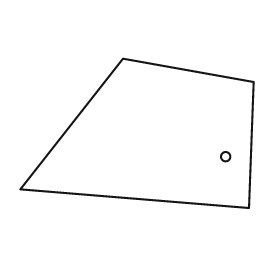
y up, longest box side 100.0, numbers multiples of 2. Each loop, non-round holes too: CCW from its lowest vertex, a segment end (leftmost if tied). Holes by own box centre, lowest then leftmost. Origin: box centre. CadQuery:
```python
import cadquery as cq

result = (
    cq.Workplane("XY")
    .moveTo(48.0, -32.0)
    .lineTo(50.0, 22.0)
    .lineTo(-6.0, 32.0)
    .lineTo(-50.0, -24.0)
    .close()
    .moveTo(38.0, -10.0)
    .circle(2.0)
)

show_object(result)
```